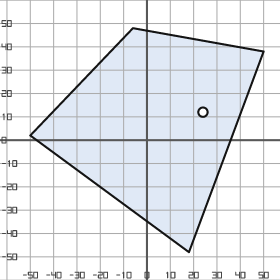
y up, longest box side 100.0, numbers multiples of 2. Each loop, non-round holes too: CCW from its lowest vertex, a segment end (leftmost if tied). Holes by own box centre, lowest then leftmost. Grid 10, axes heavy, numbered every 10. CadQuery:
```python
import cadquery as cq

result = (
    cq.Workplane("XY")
    .moveTo(18.0, -48.0)
    .lineTo(50.0, 38.0)
    .lineTo(-6.0, 48.0)
    .lineTo(-50.0, 2.0)
    .close()
    .moveTo(24.0, 12.0)
    .circle(2.0)
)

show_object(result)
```